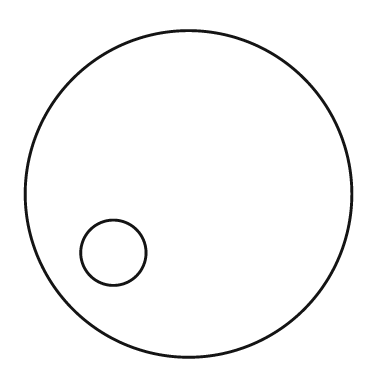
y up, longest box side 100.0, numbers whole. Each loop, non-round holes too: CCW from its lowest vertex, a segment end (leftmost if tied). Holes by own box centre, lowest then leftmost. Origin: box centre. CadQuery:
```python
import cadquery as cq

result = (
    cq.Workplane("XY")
    .moveTo(0.0, 0.0)
    .circle(50.0)
    .moveTo(-23.0, -18.0)
    .circle(10.0)
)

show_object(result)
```